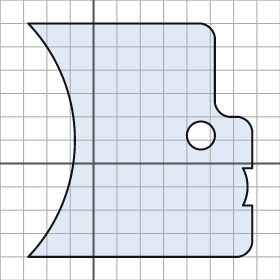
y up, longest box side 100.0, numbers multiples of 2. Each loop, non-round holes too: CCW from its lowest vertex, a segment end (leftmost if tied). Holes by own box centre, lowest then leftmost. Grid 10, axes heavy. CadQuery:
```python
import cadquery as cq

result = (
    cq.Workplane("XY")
    .moveTo(-28.0, -40.0)
    .lineTo(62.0, -40.0)
    .threePointArc((66.0, -38.0), (68.0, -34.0))
    .lineTo(68.0, -18.0)
    .lineTo(64.0, -18.0)
    .threePointArc((66.0, -10.0), (64.0, -2.0))
    .lineTo(68.0, -2.0)
    .lineTo(68.0, 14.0)
    .threePointArc((66.0, 18.0), (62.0, 20.0))
    .lineTo(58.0, 20.0)
    .threePointArc((54.0, 22.0), (52.0, 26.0))
    .lineTo(52.0, 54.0)
    .threePointArc((50.0, 58.0), (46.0, 60.0))
    .lineTo(-28.0, 60.0)
    .threePointArc((-8.0, 10.0), (-28.0, -40.0))
    .close()
    .moveTo(46.0, 12.0)
    .circle(6.0)
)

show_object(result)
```